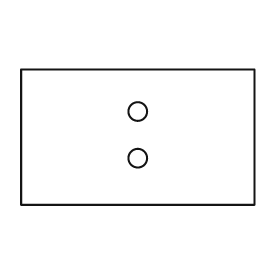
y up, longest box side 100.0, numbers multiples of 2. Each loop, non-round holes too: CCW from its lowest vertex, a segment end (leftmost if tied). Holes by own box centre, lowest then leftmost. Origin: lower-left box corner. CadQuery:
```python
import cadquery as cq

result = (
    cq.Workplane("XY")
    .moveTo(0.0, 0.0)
    .lineTo(100.0, 0.0)
    .lineTo(100.0, 58.0)
    .lineTo(0.0, 58.0)
    .close()
    .moveTo(50.0, 20.0)
    .circle(4.0)
    .moveTo(50.0, 40.0)
    .circle(4.0)
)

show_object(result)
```